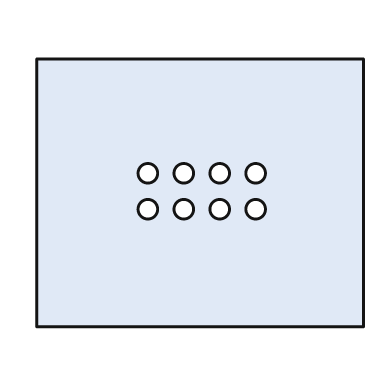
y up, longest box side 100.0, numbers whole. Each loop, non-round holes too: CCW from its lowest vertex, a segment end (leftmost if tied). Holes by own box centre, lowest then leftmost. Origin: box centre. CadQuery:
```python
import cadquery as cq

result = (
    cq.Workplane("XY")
    .moveTo(-50.0, -41.0)
    .lineTo(50.0, -41.0)
    .lineTo(50.0, 41.0)
    .lineTo(-50.0, 41.0)
    .close()
    .moveTo(-16.0, -5.0)
    .circle(3.0)
    .moveTo(-5.0, -5.0)
    .circle(3.0)
    .moveTo(6.0, -5.0)
    .circle(3.0)
    .moveTo(17.0, -5.0)
    .circle(3.0)
    .moveTo(-16.0, 6.0)
    .circle(3.0)
    .moveTo(-5.0, 6.0)
    .circle(3.0)
    .moveTo(6.0, 6.0)
    .circle(3.0)
    .moveTo(17.0, 6.0)
    .circle(3.0)
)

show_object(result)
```